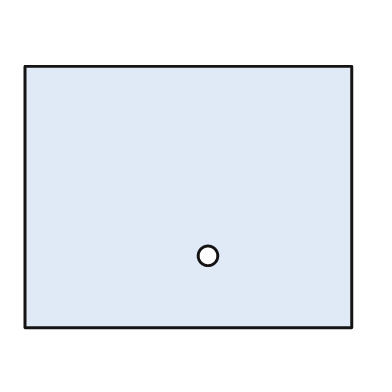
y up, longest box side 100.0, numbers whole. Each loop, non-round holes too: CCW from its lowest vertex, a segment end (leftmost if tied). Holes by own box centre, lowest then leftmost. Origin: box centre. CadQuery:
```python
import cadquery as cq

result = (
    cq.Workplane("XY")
    .moveTo(-50.0, -40.0)
    .lineTo(50.0, -40.0)
    .lineTo(50.0, 40.0)
    .lineTo(-50.0, 40.0)
    .close()
    .moveTo(6.0, -18.0)
    .circle(3.0)
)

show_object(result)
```